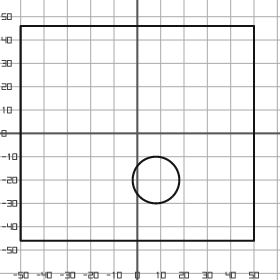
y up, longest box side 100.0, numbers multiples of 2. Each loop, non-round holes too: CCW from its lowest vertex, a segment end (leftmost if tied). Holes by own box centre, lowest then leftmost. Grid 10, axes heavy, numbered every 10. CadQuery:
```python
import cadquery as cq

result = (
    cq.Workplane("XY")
    .moveTo(-50.0, -46.0)
    .lineTo(50.0, -46.0)
    .lineTo(50.0, 46.0)
    .lineTo(-50.0, 46.0)
    .close()
    .moveTo(8.0, -20.0)
    .circle(10.0)
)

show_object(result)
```